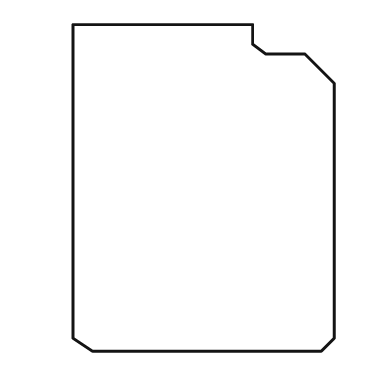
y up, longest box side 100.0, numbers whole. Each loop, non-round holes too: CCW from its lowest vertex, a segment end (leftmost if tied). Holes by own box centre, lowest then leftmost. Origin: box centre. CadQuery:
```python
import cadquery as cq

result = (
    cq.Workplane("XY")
    .moveTo(-34.0, -50.0)
    .lineTo(36.0, -50.0)
    .lineTo(40.0, -46.0)
    .lineTo(40.0, 32.0)
    .lineTo(31.0, 41.0)
    .lineTo(19.0, 41.0)
    .lineTo(15.0, 44.0)
    .lineTo(15.0, 50.0)
    .lineTo(-40.0, 50.0)
    .lineTo(-40.0, -46.0)
    .close()
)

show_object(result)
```